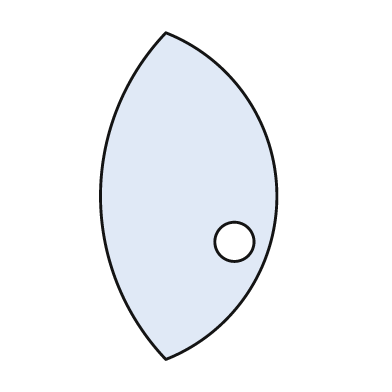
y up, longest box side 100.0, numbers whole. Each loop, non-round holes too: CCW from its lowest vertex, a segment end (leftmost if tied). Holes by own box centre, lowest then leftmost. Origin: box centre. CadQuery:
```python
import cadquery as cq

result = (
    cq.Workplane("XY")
    .moveTo(-7.0, -50.0)
    .threePointArc((27.0, 0.0), (-7.0, 50.0))
    .threePointArc((-27.0, 0.0), (-7.0, -50.0))
    .close()
    .moveTo(14.0, -14.0)
    .circle(6.0)
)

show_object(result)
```